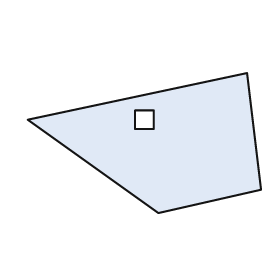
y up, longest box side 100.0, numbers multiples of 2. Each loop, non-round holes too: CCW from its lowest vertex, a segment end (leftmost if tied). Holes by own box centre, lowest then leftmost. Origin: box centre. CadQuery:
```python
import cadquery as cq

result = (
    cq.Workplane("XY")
    .moveTo(6.0, -30.0)
    .lineTo(50.0, -20.0)
    .lineTo(44.0, 30.0)
    .lineTo(-50.0, 10.0)
    .close()
    .moveTo(-4.0, 6.0)
    .lineTo(4.0, 6.0)
    .lineTo(4.0, 14.0)
    .lineTo(-4.0, 14.0)
    .close()
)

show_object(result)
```